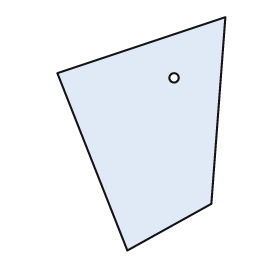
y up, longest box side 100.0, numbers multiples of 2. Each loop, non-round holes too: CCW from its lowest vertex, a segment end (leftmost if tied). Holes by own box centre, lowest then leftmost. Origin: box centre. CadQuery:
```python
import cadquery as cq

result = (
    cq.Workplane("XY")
    .moveTo(-6.0, -50.0)
    .lineTo(30.0, -30.0)
    .lineTo(36.0, 50.0)
    .lineTo(-36.0, 26.0)
    .close()
    .moveTo(14.0, 24.0)
    .circle(2.0)
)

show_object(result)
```